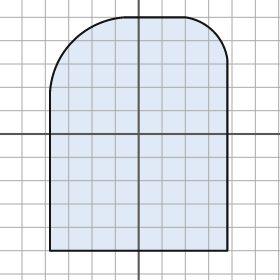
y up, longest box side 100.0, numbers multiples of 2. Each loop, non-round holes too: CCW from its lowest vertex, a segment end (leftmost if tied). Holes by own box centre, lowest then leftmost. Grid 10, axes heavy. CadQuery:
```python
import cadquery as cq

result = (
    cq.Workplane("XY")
    .moveTo(-38.0, -50.0)
    .lineTo(38.0, -50.0)
    .lineTo(38.0, 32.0)
    .threePointArc((32.0, 44.0), (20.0, 50.0))
    .lineTo(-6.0, 50.0)
    .threePointArc((-28.0, 40.0), (-38.0, 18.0))
    .close()
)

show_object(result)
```